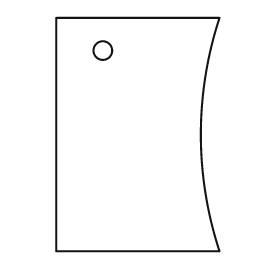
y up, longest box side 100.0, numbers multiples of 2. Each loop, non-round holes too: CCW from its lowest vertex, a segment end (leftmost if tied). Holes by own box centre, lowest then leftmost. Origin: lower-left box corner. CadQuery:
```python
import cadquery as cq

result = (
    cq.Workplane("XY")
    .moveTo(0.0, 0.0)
    .lineTo(70.0, 0.0)
    .threePointArc((62.0, 50.0), (70.0, 100.0))
    .lineTo(0.0, 100.0)
    .close()
    .moveTo(20.0, 86.0)
    .circle(4.0)
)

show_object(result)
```